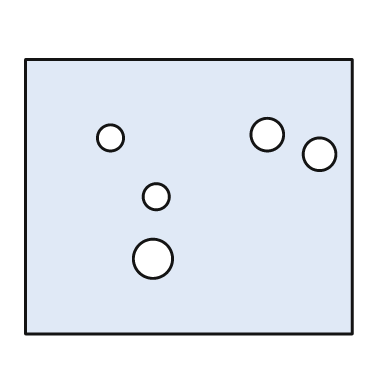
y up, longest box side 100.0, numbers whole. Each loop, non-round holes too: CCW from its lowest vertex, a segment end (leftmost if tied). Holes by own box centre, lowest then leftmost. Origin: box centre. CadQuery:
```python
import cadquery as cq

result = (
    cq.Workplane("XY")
    .moveTo(-50.0, -42.0)
    .lineTo(50.0, -42.0)
    .lineTo(50.0, 42.0)
    .lineTo(-50.0, 42.0)
    .close()
    .moveTo(-11.0, -19.0)
    .circle(6.0)
    .moveTo(-10.0, 0.0)
    .circle(4.0)
    .moveTo(40.0, 13.0)
    .circle(5.0)
    .moveTo(-24.0, 18.0)
    .circle(4.0)
    .moveTo(24.0, 19.0)
    .circle(5.0)
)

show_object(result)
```